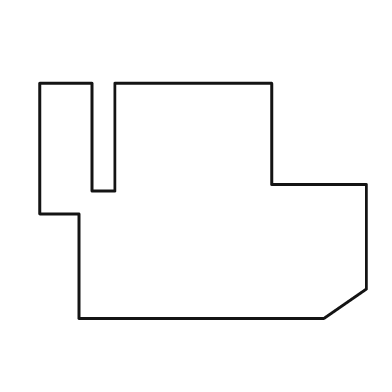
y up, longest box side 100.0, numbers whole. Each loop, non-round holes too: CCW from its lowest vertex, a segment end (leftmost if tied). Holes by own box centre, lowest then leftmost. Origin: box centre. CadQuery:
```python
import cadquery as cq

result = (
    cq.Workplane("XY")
    .moveTo(-38.0, -36.0)
    .lineTo(37.0, -36.0)
    .lineTo(50.0, -27.0)
    .lineTo(50.0, 5.0)
    .lineTo(21.0, 5.0)
    .lineTo(21.0, 36.0)
    .lineTo(-27.0, 36.0)
    .lineTo(-27.0, 3.0)
    .lineTo(-34.0, 3.0)
    .lineTo(-34.0, 36.0)
    .lineTo(-50.0, 36.0)
    .lineTo(-50.0, -4.0)
    .lineTo(-38.0, -4.0)
    .close()
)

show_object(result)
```